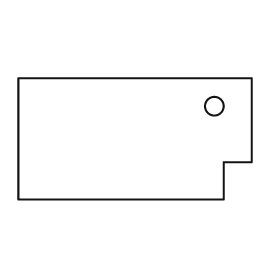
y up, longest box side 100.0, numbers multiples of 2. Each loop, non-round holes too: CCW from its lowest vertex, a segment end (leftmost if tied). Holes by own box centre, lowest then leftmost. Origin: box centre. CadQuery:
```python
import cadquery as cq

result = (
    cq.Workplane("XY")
    .moveTo(-50.0, -26.0)
    .lineTo(38.0, -26.0)
    .lineTo(38.0, -10.0)
    .lineTo(50.0, -10.0)
    .lineTo(50.0, 26.0)
    .lineTo(-50.0, 26.0)
    .close()
    .moveTo(34.0, 14.0)
    .circle(4.0)
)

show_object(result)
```